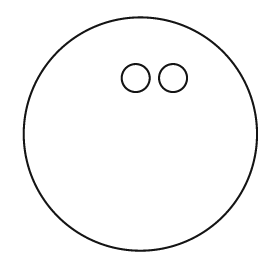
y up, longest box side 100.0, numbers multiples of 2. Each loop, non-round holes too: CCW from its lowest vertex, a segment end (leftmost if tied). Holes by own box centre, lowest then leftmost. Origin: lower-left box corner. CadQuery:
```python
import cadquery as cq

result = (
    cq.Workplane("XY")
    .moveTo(50.0, 50.0)
    .circle(50.0)
    .moveTo(48.0, 74.0)
    .circle(6.0)
    .moveTo(64.0, 74.0)
    .circle(6.0)
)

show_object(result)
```